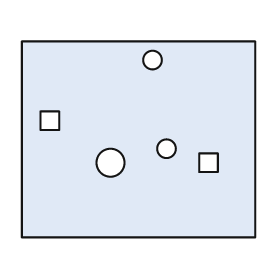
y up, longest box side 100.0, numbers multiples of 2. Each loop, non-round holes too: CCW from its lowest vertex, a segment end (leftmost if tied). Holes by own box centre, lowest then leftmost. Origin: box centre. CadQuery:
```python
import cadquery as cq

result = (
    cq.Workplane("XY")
    .moveTo(-50.0, -42.0)
    .lineTo(50.0, -42.0)
    .lineTo(50.0, 42.0)
    .lineTo(-50.0, 42.0)
    .close()
    .moveTo(-12.0, -10.0)
    .circle(6.0)
    .moveTo(26.0, -14.0)
    .lineTo(34.0, -14.0)
    .lineTo(34.0, -6.0)
    .lineTo(26.0, -6.0)
    .close()
    .moveTo(12.0, -4.0)
    .circle(4.0)
    .moveTo(-42.0, 4.0)
    .lineTo(-34.0, 4.0)
    .lineTo(-34.0, 12.0)
    .lineTo(-42.0, 12.0)
    .close()
    .moveTo(6.0, 34.0)
    .circle(4.0)
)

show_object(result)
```